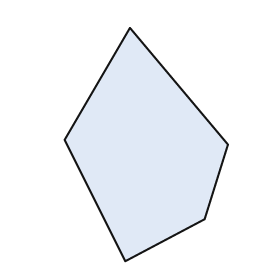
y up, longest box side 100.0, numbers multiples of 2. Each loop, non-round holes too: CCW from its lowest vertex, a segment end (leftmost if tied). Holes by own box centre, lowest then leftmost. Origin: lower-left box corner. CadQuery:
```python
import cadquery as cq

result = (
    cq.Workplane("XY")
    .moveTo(26.0, 0.0)
    .lineTo(60.0, 18.0)
    .lineTo(70.0, 50.0)
    .lineTo(28.0, 100.0)
    .lineTo(0.0, 52.0)
    .close()
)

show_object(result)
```